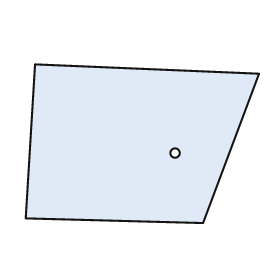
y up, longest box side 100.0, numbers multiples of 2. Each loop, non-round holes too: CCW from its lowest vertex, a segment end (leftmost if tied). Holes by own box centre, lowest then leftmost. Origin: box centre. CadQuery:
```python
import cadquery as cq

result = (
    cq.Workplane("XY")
    .moveTo(26.0, -34.0)
    .lineTo(50.0, 30.0)
    .lineTo(-46.0, 34.0)
    .lineTo(-50.0, -32.0)
    .close()
    .moveTo(14.0, -4.0)
    .circle(2.0)
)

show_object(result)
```